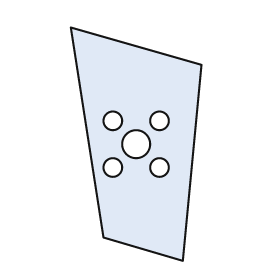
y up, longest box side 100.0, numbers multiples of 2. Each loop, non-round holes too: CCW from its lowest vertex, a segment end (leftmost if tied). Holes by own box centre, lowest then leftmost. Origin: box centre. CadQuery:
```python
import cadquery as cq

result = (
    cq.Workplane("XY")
    .moveTo(20.0, -50.0)
    .lineTo(28.0, 34.0)
    .lineTo(-28.0, 50.0)
    .lineTo(-14.0, -40.0)
    .close()
    .moveTo(-10.0, -10.0)
    .circle(4.0)
    .moveTo(10.0, -10.0)
    .circle(4.0)
    .moveTo(0.0, 0.0)
    .circle(6.0)
    .moveTo(-10.0, 10.0)
    .circle(4.0)
    .moveTo(10.0, 10.0)
    .circle(4.0)
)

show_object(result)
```